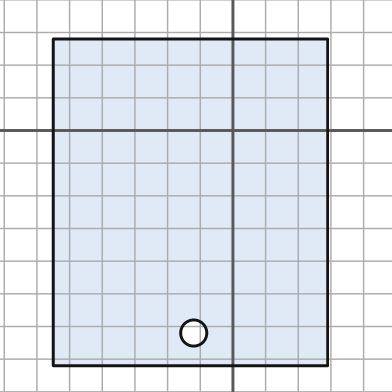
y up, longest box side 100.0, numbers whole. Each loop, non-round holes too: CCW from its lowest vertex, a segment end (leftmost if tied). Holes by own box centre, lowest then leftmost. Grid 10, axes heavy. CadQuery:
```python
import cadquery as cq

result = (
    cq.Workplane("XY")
    .moveTo(-55.0, -72.0)
    .lineTo(29.0, -72.0)
    .lineTo(29.0, 28.0)
    .lineTo(-55.0, 28.0)
    .close()
    .moveTo(-12.0, -62.0)
    .circle(4.0)
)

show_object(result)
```